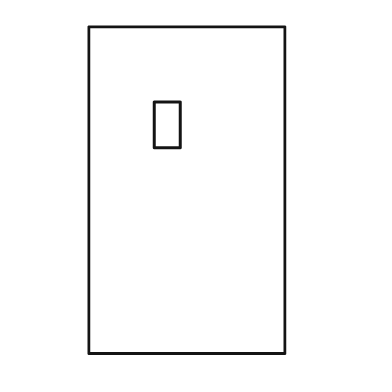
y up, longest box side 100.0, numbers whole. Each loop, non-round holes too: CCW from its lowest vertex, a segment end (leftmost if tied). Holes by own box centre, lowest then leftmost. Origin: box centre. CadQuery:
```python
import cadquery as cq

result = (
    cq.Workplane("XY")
    .moveTo(-30.0, -50.0)
    .lineTo(30.0, -50.0)
    .lineTo(30.0, 50.0)
    .lineTo(-30.0, 50.0)
    .close()
    .moveTo(-10.0, 13.0)
    .lineTo(-2.0, 13.0)
    .lineTo(-2.0, 27.0)
    .lineTo(-10.0, 27.0)
    .close()
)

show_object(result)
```